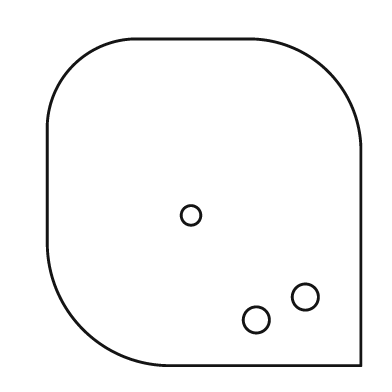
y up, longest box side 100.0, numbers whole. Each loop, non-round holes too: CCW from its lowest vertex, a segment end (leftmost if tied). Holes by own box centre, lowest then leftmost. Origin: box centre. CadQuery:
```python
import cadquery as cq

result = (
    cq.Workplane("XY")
    .moveTo(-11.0, -50.0)
    .lineTo(48.0, -50.0)
    .lineTo(48.0, 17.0)
    .threePointArc((38.0, 40.0), (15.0, 50.0))
    .lineTo(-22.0, 50.0)
    .threePointArc((-40.0, 42.0), (-48.0, 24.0))
    .lineTo(-48.0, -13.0)
    .threePointArc((-37.0, -39.0), (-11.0, -50.0))
    .close()
    .moveTo(16.0, -36.0)
    .circle(4.0)
    .moveTo(31.0, -29.0)
    .circle(4.0)
    .moveTo(-4.0, -4.0)
    .circle(3.0)
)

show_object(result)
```